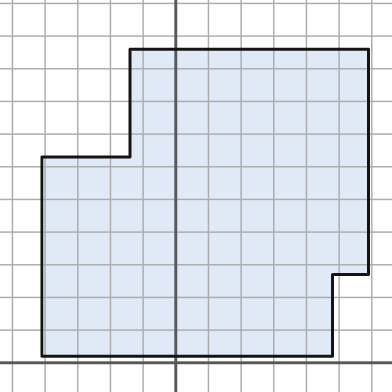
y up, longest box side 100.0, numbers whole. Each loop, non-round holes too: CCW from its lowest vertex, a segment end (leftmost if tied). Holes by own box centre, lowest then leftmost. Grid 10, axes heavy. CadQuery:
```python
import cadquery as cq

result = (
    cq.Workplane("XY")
    .moveTo(-41.0, 2.0)
    .lineTo(48.0, 2.0)
    .lineTo(48.0, 27.0)
    .lineTo(59.0, 27.0)
    .lineTo(59.0, 96.0)
    .lineTo(-14.0, 96.0)
    .lineTo(-14.0, 63.0)
    .lineTo(-41.0, 63.0)
    .close()
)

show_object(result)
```